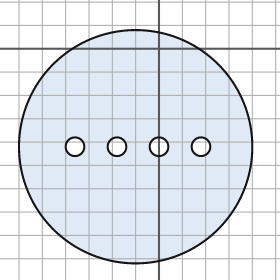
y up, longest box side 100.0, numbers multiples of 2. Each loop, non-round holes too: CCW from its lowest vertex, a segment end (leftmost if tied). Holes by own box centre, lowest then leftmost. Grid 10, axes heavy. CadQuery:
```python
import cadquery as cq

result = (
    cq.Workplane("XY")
    .moveTo(-10.0, -42.0)
    .circle(50.0)
    .moveTo(-36.0, -42.0)
    .circle(4.0)
    .moveTo(-18.0, -42.0)
    .circle(4.0)
    .moveTo(0.0, -42.0)
    .circle(4.0)
    .moveTo(18.0, -42.0)
    .circle(4.0)
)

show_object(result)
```